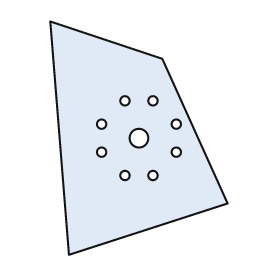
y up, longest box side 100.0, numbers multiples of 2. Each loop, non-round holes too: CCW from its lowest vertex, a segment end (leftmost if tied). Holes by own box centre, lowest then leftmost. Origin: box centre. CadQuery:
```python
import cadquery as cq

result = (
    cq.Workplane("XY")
    .moveTo(-30.0, -50.0)
    .lineTo(38.0, -28.0)
    .lineTo(10.0, 34.0)
    .lineTo(-38.0, 50.0)
    .close()
    .moveTo(-6.0, -16.0)
    .circle(2.0)
    .moveTo(6.0, -16.0)
    .circle(2.0)
    .moveTo(-16.0, -6.0)
    .circle(2.0)
    .moveTo(16.0, -6.0)
    .circle(2.0)
    .moveTo(0.0, 0.0)
    .circle(4.0)
    .moveTo(-16.0, 6.0)
    .circle(2.0)
    .moveTo(16.0, 6.0)
    .circle(2.0)
    .moveTo(-6.0, 16.0)
    .circle(2.0)
    .moveTo(6.0, 16.0)
    .circle(2.0)
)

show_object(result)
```